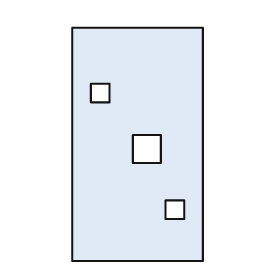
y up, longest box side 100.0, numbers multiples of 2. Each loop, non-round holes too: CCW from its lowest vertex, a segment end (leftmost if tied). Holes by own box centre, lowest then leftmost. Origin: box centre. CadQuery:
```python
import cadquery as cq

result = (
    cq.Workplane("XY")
    .moveTo(-28.0, -50.0)
    .lineTo(28.0, -50.0)
    .lineTo(28.0, 50.0)
    .lineTo(-28.0, 50.0)
    .close()
    .moveTo(12.0, -32.0)
    .lineTo(20.0, -32.0)
    .lineTo(20.0, -24.0)
    .lineTo(12.0, -24.0)
    .close()
    .moveTo(-2.0, -8.0)
    .lineTo(10.0, -8.0)
    .lineTo(10.0, 4.0)
    .lineTo(-2.0, 4.0)
    .close()
    .moveTo(-20.0, 18.0)
    .lineTo(-12.0, 18.0)
    .lineTo(-12.0, 26.0)
    .lineTo(-20.0, 26.0)
    .close()
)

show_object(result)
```